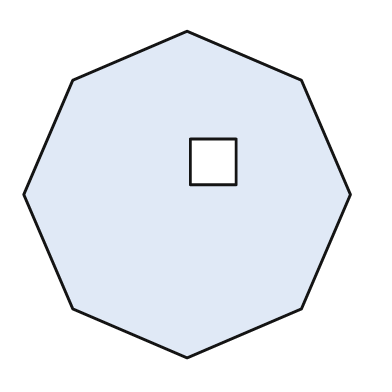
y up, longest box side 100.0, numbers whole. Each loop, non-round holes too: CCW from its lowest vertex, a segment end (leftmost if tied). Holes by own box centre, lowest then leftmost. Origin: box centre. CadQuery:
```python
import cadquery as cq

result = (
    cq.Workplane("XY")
    .moveTo(0.0, -50.0)
    .lineTo(35.0, -35.0)
    .lineTo(50.0, 0.0)
    .lineTo(35.0, 35.0)
    .lineTo(0.0, 50.0)
    .lineTo(-35.0, 35.0)
    .lineTo(-50.0, 0.0)
    .lineTo(-35.0, -35.0)
    .close()
    .moveTo(1.0, 3.0)
    .lineTo(15.0, 3.0)
    .lineTo(15.0, 17.0)
    .lineTo(1.0, 17.0)
    .close()
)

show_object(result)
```